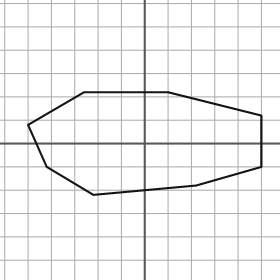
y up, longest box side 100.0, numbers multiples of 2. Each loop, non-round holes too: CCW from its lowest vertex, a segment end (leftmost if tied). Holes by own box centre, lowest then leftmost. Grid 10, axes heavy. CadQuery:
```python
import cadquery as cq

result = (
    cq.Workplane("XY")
    .moveTo(-22.0, -22.0)
    .lineTo(22.0, -18.0)
    .lineTo(50.0, -10.0)
    .lineTo(50.0, 12.0)
    .lineTo(10.0, 22.0)
    .lineTo(-26.0, 22.0)
    .lineTo(-50.0, 8.0)
    .lineTo(-42.0, -10.0)
    .close()
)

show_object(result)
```